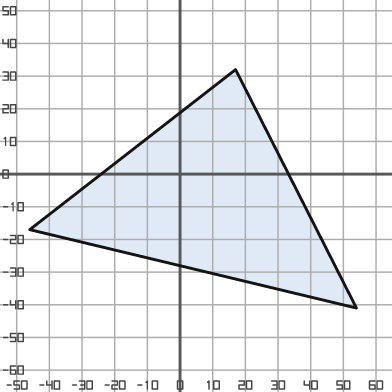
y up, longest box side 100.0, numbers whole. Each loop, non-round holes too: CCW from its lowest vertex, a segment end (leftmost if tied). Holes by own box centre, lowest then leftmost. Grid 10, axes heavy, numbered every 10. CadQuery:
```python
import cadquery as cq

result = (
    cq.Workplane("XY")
    .moveTo(54.0, -41.0)
    .lineTo(17.0, 32.0)
    .lineTo(-46.0, -17.0)
    .close()
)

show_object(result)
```